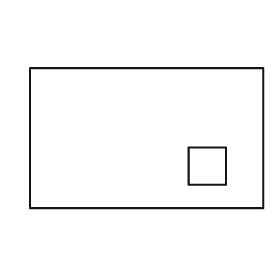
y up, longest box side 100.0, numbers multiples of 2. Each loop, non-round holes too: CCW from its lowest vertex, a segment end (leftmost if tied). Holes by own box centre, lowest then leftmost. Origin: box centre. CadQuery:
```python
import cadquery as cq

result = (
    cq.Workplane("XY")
    .moveTo(-50.0, -30.0)
    .lineTo(50.0, -30.0)
    .lineTo(50.0, 30.0)
    .lineTo(-50.0, 30.0)
    .close()
    .moveTo(18.0, -20.0)
    .lineTo(34.0, -20.0)
    .lineTo(34.0, -4.0)
    .lineTo(18.0, -4.0)
    .close()
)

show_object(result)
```